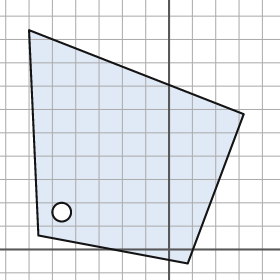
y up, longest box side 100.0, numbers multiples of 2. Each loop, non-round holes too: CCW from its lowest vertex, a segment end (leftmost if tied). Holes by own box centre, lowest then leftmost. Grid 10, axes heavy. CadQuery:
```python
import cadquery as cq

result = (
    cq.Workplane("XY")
    .moveTo(8.0, -6.0)
    .lineTo(32.0, 58.0)
    .lineTo(-60.0, 94.0)
    .lineTo(-56.0, 6.0)
    .close()
    .moveTo(-46.0, 16.0)
    .circle(4.0)
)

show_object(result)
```